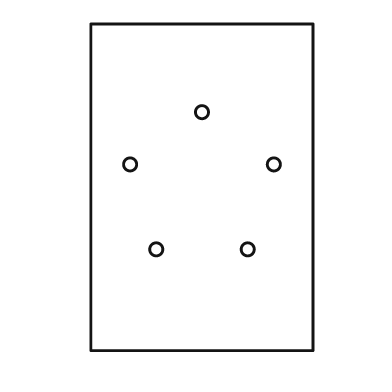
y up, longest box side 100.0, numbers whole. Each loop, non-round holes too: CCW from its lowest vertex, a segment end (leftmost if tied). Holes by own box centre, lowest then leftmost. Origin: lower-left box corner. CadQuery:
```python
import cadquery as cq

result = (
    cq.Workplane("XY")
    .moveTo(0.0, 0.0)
    .lineTo(68.0, 0.0)
    .lineTo(68.0, 100.0)
    .lineTo(0.0, 100.0)
    .close()
    .moveTo(20.0, 31.0)
    .circle(2.0)
    .moveTo(48.0, 31.0)
    .circle(2.0)
    .moveTo(12.0, 57.0)
    .circle(2.0)
    .moveTo(56.0, 57.0)
    .circle(2.0)
    .moveTo(34.0, 73.0)
    .circle(2.0)
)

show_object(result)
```